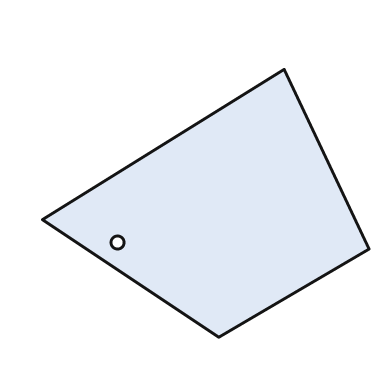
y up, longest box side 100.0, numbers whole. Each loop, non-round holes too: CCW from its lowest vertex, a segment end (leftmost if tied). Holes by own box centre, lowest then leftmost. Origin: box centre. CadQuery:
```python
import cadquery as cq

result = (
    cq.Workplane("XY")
    .moveTo(4.0, -41.0)
    .lineTo(50.0, -14.0)
    .lineTo(24.0, 41.0)
    .lineTo(-50.0, -5.0)
    .close()
    .moveTo(-27.0, -12.0)
    .circle(2.0)
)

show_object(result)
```